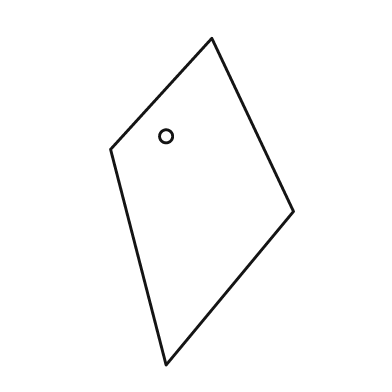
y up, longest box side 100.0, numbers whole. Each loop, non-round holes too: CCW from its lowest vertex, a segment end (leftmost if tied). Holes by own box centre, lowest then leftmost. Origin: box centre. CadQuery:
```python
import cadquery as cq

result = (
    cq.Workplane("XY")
    .moveTo(-11.0, -50.0)
    .lineTo(28.0, -3.0)
    .lineTo(3.0, 50.0)
    .lineTo(-28.0, 16.0)
    .close()
    .moveTo(-11.0, 20.0)
    .circle(2.0)
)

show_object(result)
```